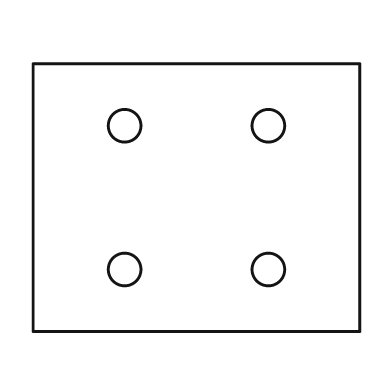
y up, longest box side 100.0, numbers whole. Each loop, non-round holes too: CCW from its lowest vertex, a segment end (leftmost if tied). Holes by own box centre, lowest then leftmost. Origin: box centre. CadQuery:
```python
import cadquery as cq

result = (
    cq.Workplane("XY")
    .moveTo(-50.0, -41.0)
    .lineTo(50.0, -41.0)
    .lineTo(50.0, 41.0)
    .lineTo(-50.0, 41.0)
    .close()
    .moveTo(-22.0, -22.0)
    .circle(5.0)
    .moveTo(22.0, -22.0)
    .circle(5.0)
    .moveTo(-22.0, 22.0)
    .circle(5.0)
    .moveTo(22.0, 22.0)
    .circle(5.0)
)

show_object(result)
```